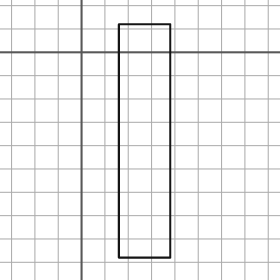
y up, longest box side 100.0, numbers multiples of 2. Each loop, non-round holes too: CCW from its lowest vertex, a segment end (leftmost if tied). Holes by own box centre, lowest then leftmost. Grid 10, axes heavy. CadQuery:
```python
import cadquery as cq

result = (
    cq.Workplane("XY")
    .moveTo(16.0, -88.0)
    .lineTo(38.0, -88.0)
    .lineTo(38.0, 12.0)
    .lineTo(16.0, 12.0)
    .close()
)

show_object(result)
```